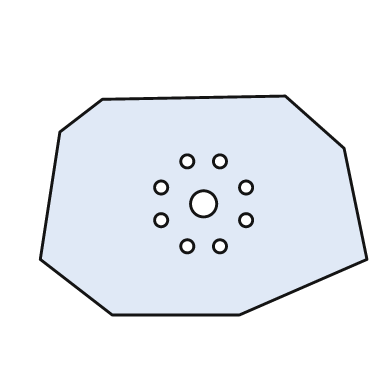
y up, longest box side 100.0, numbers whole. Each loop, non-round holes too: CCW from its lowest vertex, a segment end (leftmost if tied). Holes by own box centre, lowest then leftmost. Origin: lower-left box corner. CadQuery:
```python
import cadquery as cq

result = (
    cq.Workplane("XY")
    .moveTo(22.0, 0.0)
    .lineTo(61.0, 0.0)
    .lineTo(100.0, 17.0)
    .lineTo(93.0, 51.0)
    .lineTo(75.0, 67.0)
    .lineTo(19.0, 66.0)
    .lineTo(6.0, 56.0)
    .lineTo(0.0, 17.0)
    .close()
    .moveTo(45.0, 21.0)
    .circle(2.0)
    .moveTo(55.0, 21.0)
    .circle(2.0)
    .moveTo(37.0, 29.0)
    .circle(2.0)
    .moveTo(63.0, 29.0)
    .circle(2.0)
    .moveTo(50.0, 34.0)
    .circle(4.0)
    .moveTo(37.0, 39.0)
    .circle(2.0)
    .moveTo(63.0, 39.0)
    .circle(2.0)
    .moveTo(45.0, 47.0)
    .circle(2.0)
    .moveTo(55.0, 47.0)
    .circle(2.0)
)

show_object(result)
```